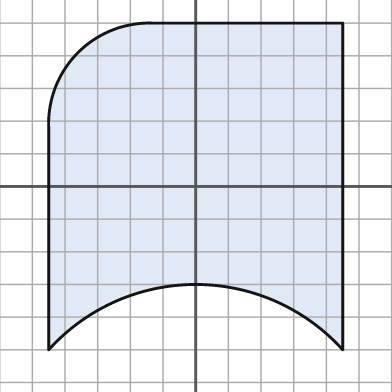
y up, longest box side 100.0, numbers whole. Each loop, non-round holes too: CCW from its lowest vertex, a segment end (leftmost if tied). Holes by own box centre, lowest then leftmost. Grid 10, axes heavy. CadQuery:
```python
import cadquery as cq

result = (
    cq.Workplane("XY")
    .moveTo(-45.0, -50.0)
    .threePointArc((0.0, -30.0), (45.0, -50.0))
    .lineTo(45.0, 50.0)
    .lineTo(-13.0, 50.0)
    .threePointArc((-36.0, 41.0), (-45.0, 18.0))
    .close()
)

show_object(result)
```